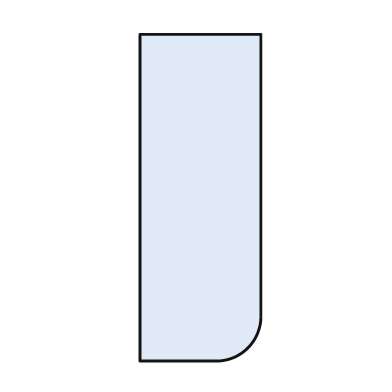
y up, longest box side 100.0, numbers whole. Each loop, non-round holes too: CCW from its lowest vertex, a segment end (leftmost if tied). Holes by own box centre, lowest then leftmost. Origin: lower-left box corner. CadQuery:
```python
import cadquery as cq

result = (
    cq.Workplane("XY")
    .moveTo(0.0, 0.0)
    .lineTo(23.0, 0.0)
    .threePointArc((33.0, 4.0), (37.0, 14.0))
    .lineTo(37.0, 100.0)
    .lineTo(0.0, 100.0)
    .close()
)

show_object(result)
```